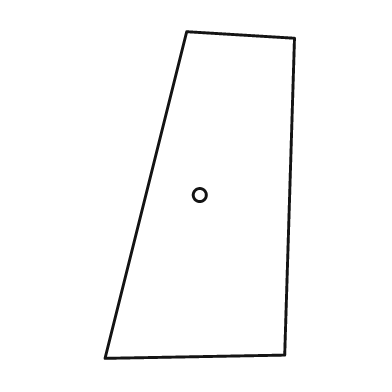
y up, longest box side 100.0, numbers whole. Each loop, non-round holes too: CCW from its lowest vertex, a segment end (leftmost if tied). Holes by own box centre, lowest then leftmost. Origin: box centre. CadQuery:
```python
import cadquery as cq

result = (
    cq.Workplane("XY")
    .moveTo(-29.0, -50.0)
    .lineTo(26.0, -49.0)
    .lineTo(29.0, 48.0)
    .lineTo(-4.0, 50.0)
    .close()
    .moveTo(0.0, 0.0)
    .circle(2.0)
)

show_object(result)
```